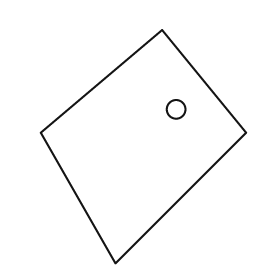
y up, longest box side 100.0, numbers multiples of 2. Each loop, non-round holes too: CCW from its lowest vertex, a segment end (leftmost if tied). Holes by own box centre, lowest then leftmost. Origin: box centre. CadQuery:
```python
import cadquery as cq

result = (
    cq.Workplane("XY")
    .moveTo(-12.0, -50.0)
    .lineTo(44.0, 6.0)
    .lineTo(8.0, 50.0)
    .lineTo(-44.0, 6.0)
    .close()
    .moveTo(14.0, 16.0)
    .circle(4.0)
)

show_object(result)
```